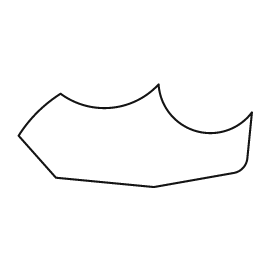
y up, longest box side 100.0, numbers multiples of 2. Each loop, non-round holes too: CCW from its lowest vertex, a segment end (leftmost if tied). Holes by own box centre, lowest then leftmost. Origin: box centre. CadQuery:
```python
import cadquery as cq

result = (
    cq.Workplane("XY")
    .moveTo(8.0, -22.0)
    .lineTo(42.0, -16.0)
    .threePointArc((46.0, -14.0), (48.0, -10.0))
    .lineTo(50.0, 10.0)
    .threePointArc((26.0, 2.0), (10.0, 22.0))
    .threePointArc((-10.0, 12.0), (-32.0, 18.0))
    .threePointArc((-42.0, 10.0), (-50.0, 0.0))
    .lineTo(-34.0, -18.0)
    .close()
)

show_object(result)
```